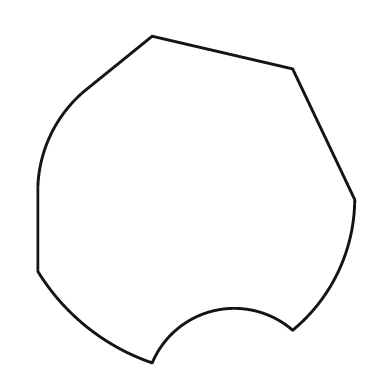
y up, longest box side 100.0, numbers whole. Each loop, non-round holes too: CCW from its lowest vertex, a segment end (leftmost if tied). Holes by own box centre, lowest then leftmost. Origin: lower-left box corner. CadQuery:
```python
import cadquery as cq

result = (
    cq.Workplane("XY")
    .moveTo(35.0, 0.0)
    .threePointArc((54.0, 16.0), (78.0, 10.0))
    .threePointArc((92.0, 28.0), (97.0, 50.0))
    .lineTo(78.0, 90.0)
    .lineTo(35.0, 100.0)
    .lineTo(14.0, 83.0)
    .threePointArc((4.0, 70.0), (0.0, 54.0))
    .lineTo(0.0, 28.0)
    .threePointArc((15.0, 11.0), (35.0, 0.0))
    .close()
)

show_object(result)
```